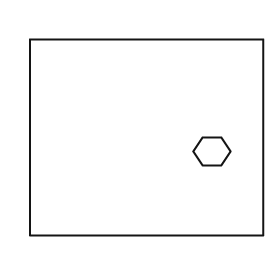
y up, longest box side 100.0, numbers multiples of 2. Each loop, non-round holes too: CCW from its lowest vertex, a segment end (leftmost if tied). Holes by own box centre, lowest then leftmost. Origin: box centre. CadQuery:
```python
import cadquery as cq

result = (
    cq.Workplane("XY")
    .moveTo(-50.0, -42.0)
    .lineTo(50.0, -42.0)
    .lineTo(50.0, 42.0)
    .lineTo(-50.0, 42.0)
    .close()
    .moveTo(24.0, -12.0)
    .lineTo(32.0, -12.0)
    .lineTo(36.0, -6.0)
    .lineTo(32.0, 0.0)
    .lineTo(24.0, 0.0)
    .lineTo(20.0, -6.0)
    .close()
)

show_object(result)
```